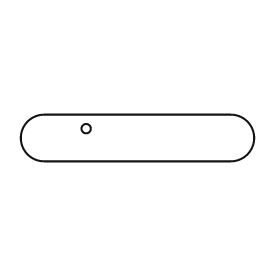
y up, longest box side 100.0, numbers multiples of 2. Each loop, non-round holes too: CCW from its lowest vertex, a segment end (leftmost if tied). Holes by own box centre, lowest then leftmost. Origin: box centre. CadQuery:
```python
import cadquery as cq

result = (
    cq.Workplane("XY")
    .moveTo(-40.0, -10.0)
    .lineTo(40.0, -10.0)
    .threePointArc((50.0, 0.0), (40.0, 10.0))
    .lineTo(-40.0, 10.0)
    .threePointArc((-50.0, 0.0), (-40.0, -10.0))
    .close()
    .moveTo(-22.0, 4.0)
    .circle(2.0)
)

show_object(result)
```